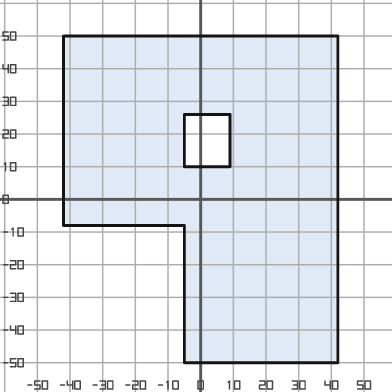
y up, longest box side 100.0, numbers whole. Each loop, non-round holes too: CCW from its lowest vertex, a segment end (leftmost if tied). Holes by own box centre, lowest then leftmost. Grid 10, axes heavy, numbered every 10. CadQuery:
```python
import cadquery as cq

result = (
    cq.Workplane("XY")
    .moveTo(-5.0, -50.0)
    .lineTo(42.0, -50.0)
    .lineTo(42.0, 50.0)
    .lineTo(-42.0, 50.0)
    .lineTo(-42.0, -8.0)
    .lineTo(-5.0, -8.0)
    .close()
    .moveTo(-5.0, 10.0)
    .lineTo(9.0, 10.0)
    .lineTo(9.0, 26.0)
    .lineTo(-5.0, 26.0)
    .close()
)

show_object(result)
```